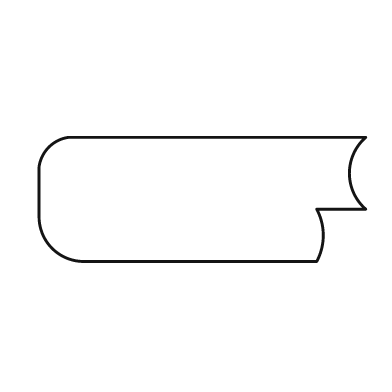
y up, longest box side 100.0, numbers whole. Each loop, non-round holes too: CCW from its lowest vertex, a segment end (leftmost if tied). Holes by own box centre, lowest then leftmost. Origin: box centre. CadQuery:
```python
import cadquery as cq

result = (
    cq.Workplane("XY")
    .moveTo(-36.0, -19.0)
    .lineTo(35.0, -19.0)
    .threePointArc((37.0, -11.0), (35.0, -3.0))
    .lineTo(50.0, -3.0)
    .threePointArc((45.0, 8.0), (50.0, 19.0))
    .lineTo(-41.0, 19.0)
    .threePointArc((-47.0, 16.0), (-50.0, 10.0))
    .lineTo(-50.0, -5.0)
    .threePointArc((-46.0, -15.0), (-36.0, -19.0))
    .close()
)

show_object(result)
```